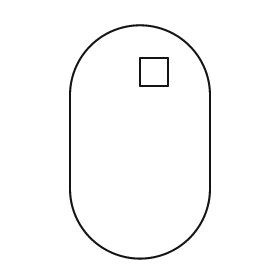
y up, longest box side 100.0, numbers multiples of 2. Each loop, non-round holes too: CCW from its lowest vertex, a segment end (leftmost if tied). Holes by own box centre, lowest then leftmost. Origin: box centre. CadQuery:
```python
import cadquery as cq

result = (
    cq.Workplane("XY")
    .moveTo(-30.0, -20.0)
    .threePointArc((0.0, -50.0), (30.0, -20.0))
    .lineTo(30.0, 20.0)
    .threePointArc((0.0, 50.0), (-30.0, 20.0))
    .close()
    .moveTo(0.0, 24.0)
    .lineTo(12.0, 24.0)
    .lineTo(12.0, 36.0)
    .lineTo(0.0, 36.0)
    .close()
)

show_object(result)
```